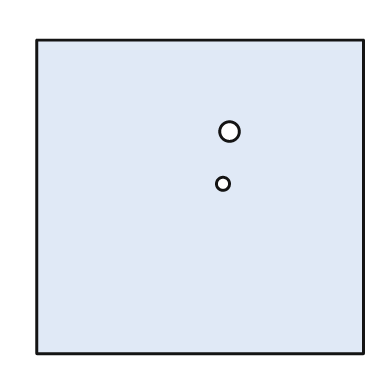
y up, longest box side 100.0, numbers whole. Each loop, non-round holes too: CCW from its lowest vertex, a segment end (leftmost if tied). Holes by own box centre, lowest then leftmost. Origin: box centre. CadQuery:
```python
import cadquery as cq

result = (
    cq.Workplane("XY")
    .moveTo(-50.0, -48.0)
    .lineTo(50.0, -48.0)
    .lineTo(50.0, 48.0)
    .lineTo(-50.0, 48.0)
    .close()
    .moveTo(7.0, 4.0)
    .circle(2.0)
    .moveTo(9.0, 20.0)
    .circle(3.0)
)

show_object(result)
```